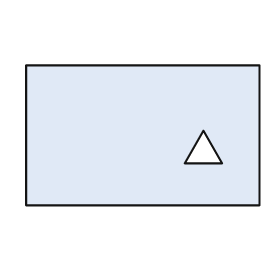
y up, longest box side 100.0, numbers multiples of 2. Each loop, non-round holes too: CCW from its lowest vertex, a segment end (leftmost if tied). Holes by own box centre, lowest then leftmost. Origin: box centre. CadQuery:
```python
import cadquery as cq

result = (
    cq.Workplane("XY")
    .moveTo(-50.0, -30.0)
    .lineTo(50.0, -30.0)
    .lineTo(50.0, 30.0)
    .lineTo(-50.0, 30.0)
    .close()
    .moveTo(18.0, -12.0)
    .lineTo(34.0, -12.0)
    .lineTo(26.0, 2.0)
    .close()
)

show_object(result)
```